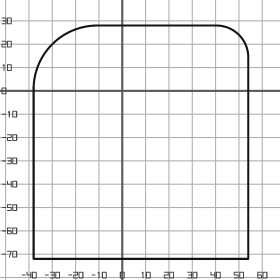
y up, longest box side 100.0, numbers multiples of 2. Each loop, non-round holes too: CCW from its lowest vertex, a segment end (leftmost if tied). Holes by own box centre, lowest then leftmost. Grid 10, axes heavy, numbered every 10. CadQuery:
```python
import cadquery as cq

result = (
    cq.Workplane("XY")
    .moveTo(-38.0, -72.0)
    .lineTo(54.0, -72.0)
    .lineTo(54.0, 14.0)
    .threePointArc((50.0, 24.0), (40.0, 28.0))
    .lineTo(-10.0, 28.0)
    .threePointArc((-30.0, 20.0), (-38.0, 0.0))
    .close()
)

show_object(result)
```